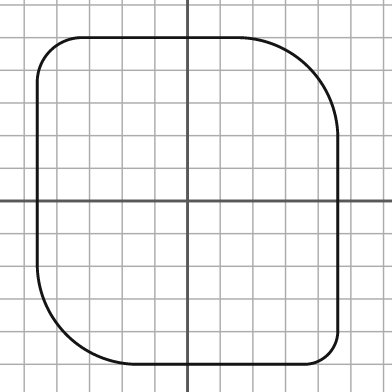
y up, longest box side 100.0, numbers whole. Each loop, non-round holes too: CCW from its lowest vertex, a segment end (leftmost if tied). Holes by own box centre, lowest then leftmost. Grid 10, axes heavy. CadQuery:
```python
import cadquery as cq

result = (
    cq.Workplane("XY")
    .moveTo(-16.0, -50.0)
    .lineTo(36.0, -50.0)
    .threePointArc((43.0, -47.0), (46.0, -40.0))
    .lineTo(46.0, 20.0)
    .threePointArc((37.0, 41.0), (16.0, 50.0))
    .lineTo(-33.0, 50.0)
    .threePointArc((-42.0, 46.0), (-46.0, 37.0))
    .lineTo(-46.0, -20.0)
    .threePointArc((-37.0, -41.0), (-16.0, -50.0))
    .close()
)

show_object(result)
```